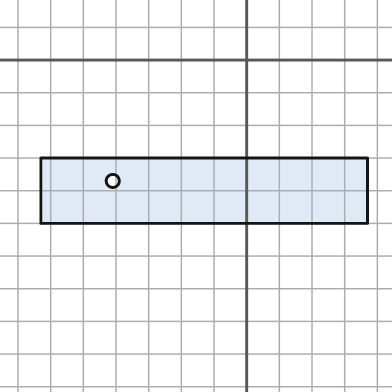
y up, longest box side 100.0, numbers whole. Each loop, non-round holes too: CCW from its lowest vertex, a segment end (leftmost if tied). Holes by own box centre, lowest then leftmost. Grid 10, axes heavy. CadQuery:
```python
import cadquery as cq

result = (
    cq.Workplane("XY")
    .moveTo(-63.0, -50.0)
    .lineTo(37.0, -50.0)
    .lineTo(37.0, -30.0)
    .lineTo(-63.0, -30.0)
    .close()
    .moveTo(-41.0, -37.0)
    .circle(2.0)
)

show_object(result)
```